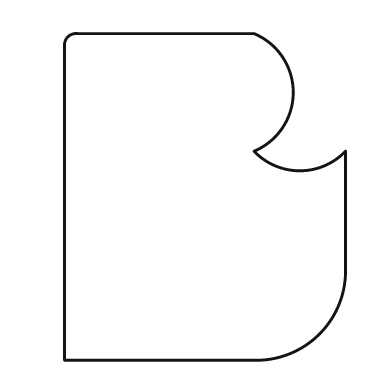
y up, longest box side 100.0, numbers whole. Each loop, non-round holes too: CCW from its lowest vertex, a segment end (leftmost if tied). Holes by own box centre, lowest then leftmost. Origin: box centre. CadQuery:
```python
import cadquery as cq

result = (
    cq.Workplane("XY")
    .moveTo(-43.0, -50.0)
    .lineTo(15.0, -50.0)
    .threePointArc((35.0, -42.0), (43.0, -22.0))
    .lineTo(43.0, 14.0)
    .threePointArc((29.0, 8.0), (15.0, 14.0))
    .threePointArc((27.0, 32.0), (15.0, 50.0))
    .lineTo(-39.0, 50.0)
    .threePointArc((-42.0, 49.0), (-43.0, 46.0))
    .close()
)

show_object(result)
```